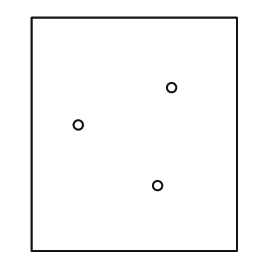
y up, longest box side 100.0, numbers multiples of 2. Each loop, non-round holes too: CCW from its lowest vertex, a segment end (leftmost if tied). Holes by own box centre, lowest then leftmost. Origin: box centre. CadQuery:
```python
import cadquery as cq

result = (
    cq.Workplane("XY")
    .moveTo(-44.0, -50.0)
    .lineTo(44.0, -50.0)
    .lineTo(44.0, 50.0)
    .lineTo(-44.0, 50.0)
    .close()
    .moveTo(10.0, -22.0)
    .circle(2.0)
    .moveTo(-24.0, 4.0)
    .circle(2.0)
    .moveTo(16.0, 20.0)
    .circle(2.0)
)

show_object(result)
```